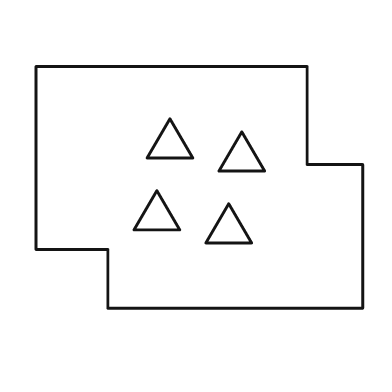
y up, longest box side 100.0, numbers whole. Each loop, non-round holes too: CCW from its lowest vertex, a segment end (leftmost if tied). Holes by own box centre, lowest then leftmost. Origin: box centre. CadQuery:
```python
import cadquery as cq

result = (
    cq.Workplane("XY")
    .moveTo(-28.0, -37.0)
    .lineTo(50.0, -37.0)
    .lineTo(50.0, 7.0)
    .lineTo(33.0, 7.0)
    .lineTo(33.0, 37.0)
    .lineTo(-50.0, 37.0)
    .lineTo(-50.0, -19.0)
    .lineTo(-28.0, -19.0)
    .close()
    .moveTo(2.0, -17.0)
    .lineTo(16.0, -17.0)
    .lineTo(9.0, -5.0)
    .close()
    .moveTo(-20.0, -13.0)
    .lineTo(-6.0, -13.0)
    .lineTo(-13.0, -1.0)
    .close()
    .moveTo(6.0, 5.0)
    .lineTo(20.0, 5.0)
    .lineTo(13.0, 17.0)
    .close()
    .moveTo(-16.0, 9.0)
    .lineTo(-2.0, 9.0)
    .lineTo(-9.0, 21.0)
    .close()
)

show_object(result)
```